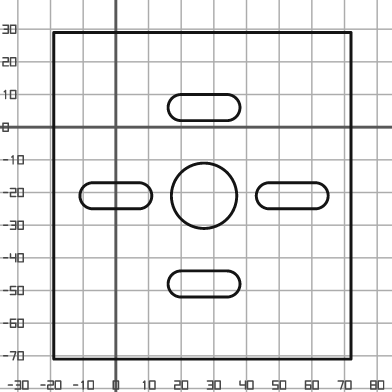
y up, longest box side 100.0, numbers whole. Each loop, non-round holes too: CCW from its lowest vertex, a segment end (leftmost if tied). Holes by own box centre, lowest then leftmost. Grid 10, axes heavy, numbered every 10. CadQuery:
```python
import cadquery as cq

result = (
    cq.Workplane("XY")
    .moveTo(-19.0, -71.0)
    .lineTo(72.0, -71.0)
    .lineTo(72.0, 29.0)
    .lineTo(-19.0, 29.0)
    .close()
    .moveTo(20.0, -52.0)
    .lineTo(34.0, -52.0)
    .threePointArc((38.0, -48.0), (34.0, -44.0))
    .lineTo(20.0, -44.0)
    .threePointArc((16.0, -48.0), (20.0, -52.0))
    .close()
    .moveTo(-7.0, -25.0)
    .lineTo(7.0, -25.0)
    .threePointArc((11.0, -21.0), (7.0, -17.0))
    .lineTo(-7.0, -17.0)
    .threePointArc((-11.0, -21.0), (-7.0, -25.0))
    .close()
    .moveTo(27.0, -21.0)
    .circle(10.0)
    .moveTo(47.0, -25.0)
    .lineTo(61.0, -25.0)
    .threePointArc((65.0, -21.0), (61.0, -17.0))
    .lineTo(47.0, -17.0)
    .threePointArc((43.0, -21.0), (47.0, -25.0))
    .close()
    .moveTo(20.0, 2.0)
    .lineTo(34.0, 2.0)
    .threePointArc((38.0, 6.0), (34.0, 10.0))
    .lineTo(20.0, 10.0)
    .threePointArc((16.0, 6.0), (20.0, 2.0))
    .close()
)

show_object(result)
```